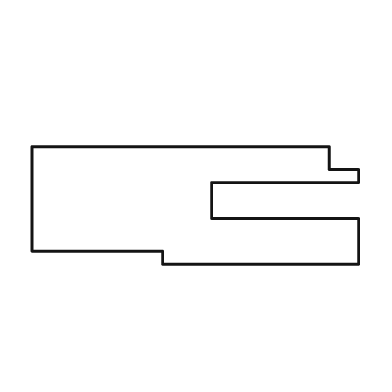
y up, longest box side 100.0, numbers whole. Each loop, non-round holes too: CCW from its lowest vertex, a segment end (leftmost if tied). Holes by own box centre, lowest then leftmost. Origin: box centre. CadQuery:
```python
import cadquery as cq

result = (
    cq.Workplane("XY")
    .moveTo(-10.0, -18.0)
    .lineTo(50.0, -18.0)
    .lineTo(50.0, -4.0)
    .lineTo(5.0, -4.0)
    .lineTo(5.0, 7.0)
    .lineTo(50.0, 7.0)
    .lineTo(50.0, 11.0)
    .lineTo(41.0, 11.0)
    .lineTo(41.0, 18.0)
    .lineTo(-50.0, 18.0)
    .lineTo(-50.0, -14.0)
    .lineTo(-10.0, -14.0)
    .close()
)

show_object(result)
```